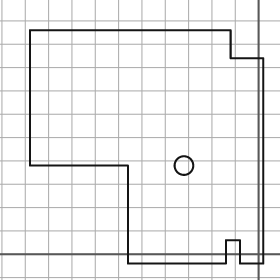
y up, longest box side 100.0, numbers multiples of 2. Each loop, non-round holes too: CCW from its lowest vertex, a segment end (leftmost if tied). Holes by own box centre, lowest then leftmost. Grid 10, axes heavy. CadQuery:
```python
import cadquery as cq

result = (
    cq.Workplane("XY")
    .moveTo(-56.0, -4.0)
    .lineTo(-14.0, -4.0)
    .lineTo(-14.0, 6.0)
    .lineTo(-8.0, 6.0)
    .lineTo(-8.0, -4.0)
    .lineTo(2.0, -4.0)
    .lineTo(2.0, 84.0)
    .lineTo(-12.0, 84.0)
    .lineTo(-12.0, 96.0)
    .lineTo(-98.0, 96.0)
    .lineTo(-98.0, 38.0)
    .lineTo(-56.0, 38.0)
    .close()
    .moveTo(-32.0, 38.0)
    .circle(4.0)
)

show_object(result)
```